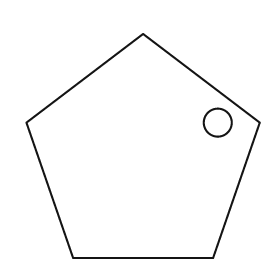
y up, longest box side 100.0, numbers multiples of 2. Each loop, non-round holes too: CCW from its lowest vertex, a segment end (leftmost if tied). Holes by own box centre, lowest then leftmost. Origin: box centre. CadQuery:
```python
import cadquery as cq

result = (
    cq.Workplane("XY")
    .moveTo(-30.0, -48.0)
    .lineTo(30.0, -48.0)
    .lineTo(50.0, 10.0)
    .lineTo(0.0, 48.0)
    .lineTo(-50.0, 10.0)
    .close()
    .moveTo(32.0, 10.0)
    .circle(6.0)
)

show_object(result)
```